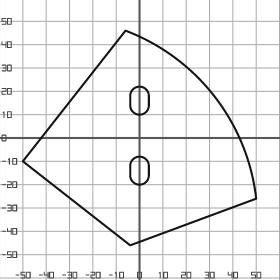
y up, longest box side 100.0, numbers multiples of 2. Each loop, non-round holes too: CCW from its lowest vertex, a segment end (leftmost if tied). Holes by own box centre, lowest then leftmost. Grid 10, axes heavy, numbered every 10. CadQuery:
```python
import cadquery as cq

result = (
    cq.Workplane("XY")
    .moveTo(-4.0, -46.0)
    .lineTo(50.0, -26.0)
    .threePointArc((32.0, 18.0), (-6.0, 46.0))
    .lineTo(-50.0, -10.0)
    .close()
    .moveTo(-4.0, -16.0)
    .threePointArc((0.0, -20.0), (4.0, -16.0))
    .lineTo(4.0, -12.0)
    .threePointArc((0.0, -8.0), (-4.0, -12.0))
    .close()
    .moveTo(-4.0, 14.0)
    .threePointArc((0.0, 10.0), (4.0, 14.0))
    .lineTo(4.0, 18.0)
    .threePointArc((0.0, 22.0), (-4.0, 18.0))
    .close()
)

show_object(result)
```